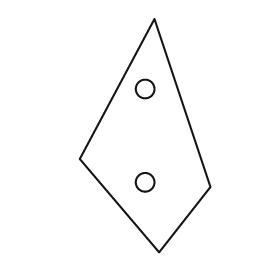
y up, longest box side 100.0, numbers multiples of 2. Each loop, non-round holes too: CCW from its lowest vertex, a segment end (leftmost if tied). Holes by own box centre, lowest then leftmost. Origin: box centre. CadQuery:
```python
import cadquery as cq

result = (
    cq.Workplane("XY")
    .moveTo(6.0, -50.0)
    .lineTo(28.0, -22.0)
    .lineTo(4.0, 50.0)
    .lineTo(-28.0, -10.0)
    .close()
    .moveTo(0.0, -20.0)
    .circle(4.0)
    .moveTo(0.0, 20.0)
    .circle(4.0)
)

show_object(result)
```